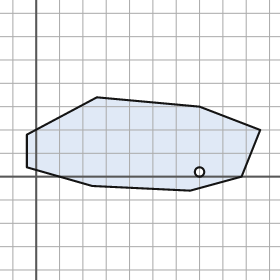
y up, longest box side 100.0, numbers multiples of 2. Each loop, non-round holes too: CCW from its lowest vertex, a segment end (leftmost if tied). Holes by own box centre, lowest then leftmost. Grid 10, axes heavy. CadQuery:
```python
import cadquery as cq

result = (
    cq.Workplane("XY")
    .moveTo(66.0, -6.0)
    .lineTo(88.0, 0.0)
    .lineTo(96.0, 20.0)
    .lineTo(70.0, 30.0)
    .lineTo(26.0, 34.0)
    .lineTo(-4.0, 18.0)
    .lineTo(-4.0, 4.0)
    .lineTo(24.0, -4.0)
    .close()
    .moveTo(70.0, 2.0)
    .circle(2.0)
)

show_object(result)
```